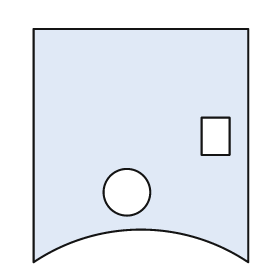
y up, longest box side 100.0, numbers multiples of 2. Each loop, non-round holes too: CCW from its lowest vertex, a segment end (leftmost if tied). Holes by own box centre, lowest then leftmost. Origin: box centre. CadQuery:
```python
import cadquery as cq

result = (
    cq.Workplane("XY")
    .moveTo(-46.0, -50.0)
    .threePointArc((0.0, -36.0), (46.0, -50.0))
    .lineTo(46.0, 50.0)
    .lineTo(-46.0, 50.0)
    .close()
    .moveTo(-6.0, -20.0)
    .circle(10.0)
    .moveTo(26.0, -4.0)
    .lineTo(38.0, -4.0)
    .lineTo(38.0, 12.0)
    .lineTo(26.0, 12.0)
    .close()
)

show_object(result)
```